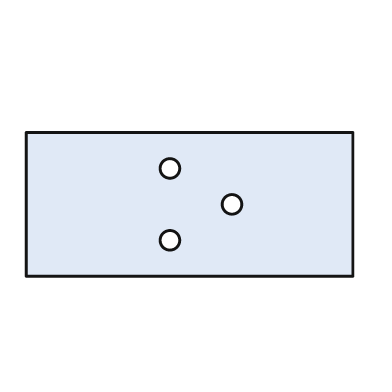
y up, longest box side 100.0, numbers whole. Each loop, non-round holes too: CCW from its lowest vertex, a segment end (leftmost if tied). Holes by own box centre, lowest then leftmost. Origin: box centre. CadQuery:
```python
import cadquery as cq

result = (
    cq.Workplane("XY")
    .moveTo(-50.0, -22.0)
    .lineTo(50.0, -22.0)
    .lineTo(50.0, 22.0)
    .lineTo(-50.0, 22.0)
    .close()
    .moveTo(-6.0, -11.0)
    .circle(3.0)
    .moveTo(13.0, 0.0)
    .circle(3.0)
    .moveTo(-6.0, 11.0)
    .circle(3.0)
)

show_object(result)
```